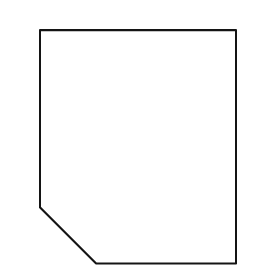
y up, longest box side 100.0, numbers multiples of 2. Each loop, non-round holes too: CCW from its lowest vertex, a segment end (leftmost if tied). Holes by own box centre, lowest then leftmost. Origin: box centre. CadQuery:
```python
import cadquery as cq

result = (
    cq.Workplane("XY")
    .moveTo(-18.0, -50.0)
    .lineTo(42.0, -50.0)
    .lineTo(42.0, 50.0)
    .lineTo(-42.0, 50.0)
    .lineTo(-42.0, -26.0)
    .close()
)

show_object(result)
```